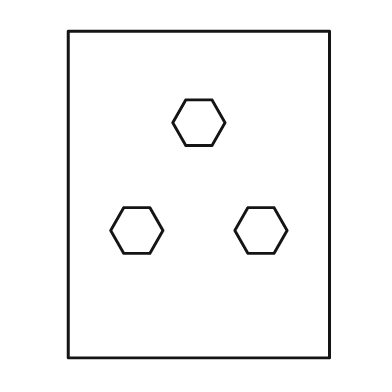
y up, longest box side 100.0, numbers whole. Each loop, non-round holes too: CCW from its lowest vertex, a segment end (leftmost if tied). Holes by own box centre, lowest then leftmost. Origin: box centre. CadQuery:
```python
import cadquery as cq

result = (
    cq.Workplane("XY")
    .moveTo(-40.0, -50.0)
    .lineTo(40.0, -50.0)
    .lineTo(40.0, 50.0)
    .lineTo(-40.0, 50.0)
    .close()
    .moveTo(-23.0, -18.0)
    .lineTo(-15.0, -18.0)
    .lineTo(-11.0, -11.0)
    .lineTo(-15.0, -4.0)
    .lineTo(-23.0, -4.0)
    .lineTo(-27.0, -11.0)
    .close()
    .moveTo(15.0, -18.0)
    .lineTo(23.0, -18.0)
    .lineTo(27.0, -11.0)
    .lineTo(23.0, -4.0)
    .lineTo(15.0, -4.0)
    .lineTo(11.0, -11.0)
    .close()
    .moveTo(-4.0, 15.0)
    .lineTo(4.0, 15.0)
    .lineTo(8.0, 22.0)
    .lineTo(4.0, 29.0)
    .lineTo(-4.0, 29.0)
    .lineTo(-8.0, 22.0)
    .close()
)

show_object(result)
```